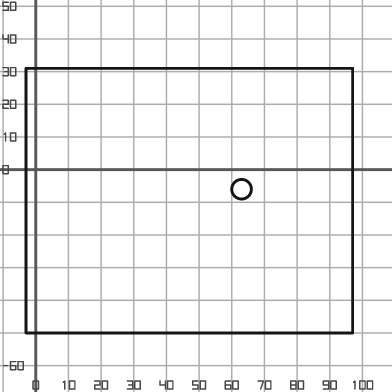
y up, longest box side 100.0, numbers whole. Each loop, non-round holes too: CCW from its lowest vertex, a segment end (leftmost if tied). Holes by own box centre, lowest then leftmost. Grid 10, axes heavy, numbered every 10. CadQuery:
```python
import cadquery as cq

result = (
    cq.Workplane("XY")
    .moveTo(-3.0, -50.0)
    .lineTo(97.0, -50.0)
    .lineTo(97.0, 31.0)
    .lineTo(-3.0, 31.0)
    .close()
    .moveTo(63.0, -6.0)
    .circle(3.0)
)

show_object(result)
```